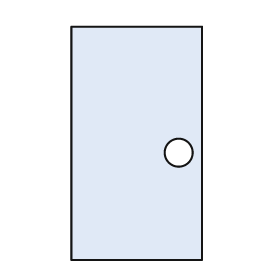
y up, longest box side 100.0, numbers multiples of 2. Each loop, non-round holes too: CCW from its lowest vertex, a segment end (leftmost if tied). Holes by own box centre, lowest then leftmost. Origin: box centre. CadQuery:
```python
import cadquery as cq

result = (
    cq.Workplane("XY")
    .moveTo(-28.0, -50.0)
    .lineTo(28.0, -50.0)
    .lineTo(28.0, 50.0)
    .lineTo(-28.0, 50.0)
    .close()
    .moveTo(18.0, -4.0)
    .circle(6.0)
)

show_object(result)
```